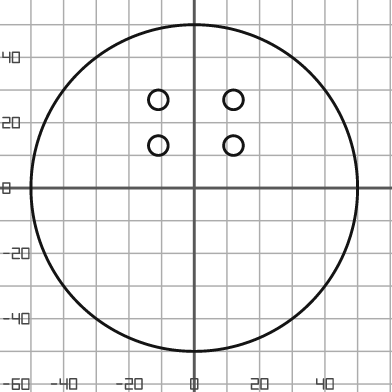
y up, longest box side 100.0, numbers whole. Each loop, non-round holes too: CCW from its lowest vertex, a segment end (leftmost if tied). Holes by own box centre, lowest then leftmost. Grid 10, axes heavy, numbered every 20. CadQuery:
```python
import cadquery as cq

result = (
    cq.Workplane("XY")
    .moveTo(0.0, 0.0)
    .circle(50.0)
    .moveTo(-11.0, 13.0)
    .circle(3.0)
    .moveTo(12.0, 13.0)
    .circle(3.0)
    .moveTo(-11.0, 27.0)
    .circle(3.0)
    .moveTo(12.0, 27.0)
    .circle(3.0)
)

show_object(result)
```